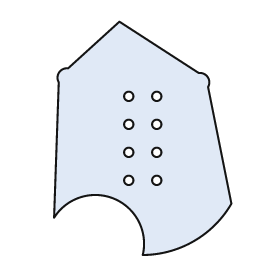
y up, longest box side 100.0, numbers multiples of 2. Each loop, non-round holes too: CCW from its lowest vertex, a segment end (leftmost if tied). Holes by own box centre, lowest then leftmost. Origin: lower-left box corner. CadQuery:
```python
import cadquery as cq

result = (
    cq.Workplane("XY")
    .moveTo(38.0, 0.0)
    .threePointArc((60.0, 6.0), (76.0, 22.0))
    .lineTo(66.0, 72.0)
    .threePointArc((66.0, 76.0), (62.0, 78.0))
    .lineTo(28.0, 100.0)
    .lineTo(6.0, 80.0)
    .threePointArc((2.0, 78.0), (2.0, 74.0))
    .lineTo(0.0, 16.0)
    .threePointArc((26.0, 24.0), (38.0, 0.0))
    .close()
    .moveTo(32.0, 32.0)
    .circle(2.0)
    .moveTo(44.0, 32.0)
    .circle(2.0)
    .moveTo(32.0, 44.0)
    .circle(2.0)
    .moveTo(44.0, 44.0)
    .circle(2.0)
    .moveTo(32.0, 56.0)
    .circle(2.0)
    .moveTo(44.0, 56.0)
    .circle(2.0)
    .moveTo(32.0, 68.0)
    .circle(2.0)
    .moveTo(44.0, 68.0)
    .circle(2.0)
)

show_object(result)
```